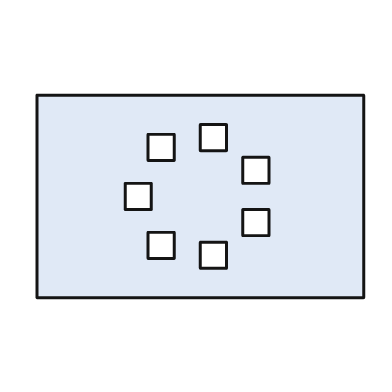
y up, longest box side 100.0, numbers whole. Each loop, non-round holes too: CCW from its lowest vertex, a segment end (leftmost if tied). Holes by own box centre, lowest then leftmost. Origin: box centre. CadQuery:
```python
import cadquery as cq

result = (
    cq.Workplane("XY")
    .moveTo(-50.0, -31.0)
    .lineTo(50.0, -31.0)
    .lineTo(50.0, 31.0)
    .lineTo(-50.0, 31.0)
    .close()
    .moveTo(0.0, -22.0)
    .lineTo(8.0, -22.0)
    .lineTo(8.0, -14.0)
    .lineTo(0.0, -14.0)
    .close()
    .moveTo(-16.0, -19.0)
    .lineTo(-8.0, -19.0)
    .lineTo(-8.0, -11.0)
    .lineTo(-16.0, -11.0)
    .close()
    .moveTo(13.0, -12.0)
    .lineTo(21.0, -12.0)
    .lineTo(21.0, -4.0)
    .lineTo(13.0, -4.0)
    .close()
    .moveTo(-23.0, -4.0)
    .lineTo(-15.0, -4.0)
    .lineTo(-15.0, 4.0)
    .lineTo(-23.0, 4.0)
    .close()
    .moveTo(13.0, 4.0)
    .lineTo(21.0, 4.0)
    .lineTo(21.0, 12.0)
    .lineTo(13.0, 12.0)
    .close()
    .moveTo(-16.0, 11.0)
    .lineTo(-8.0, 11.0)
    .lineTo(-8.0, 19.0)
    .lineTo(-16.0, 19.0)
    .close()
    .moveTo(0.0, 14.0)
    .lineTo(8.0, 14.0)
    .lineTo(8.0, 22.0)
    .lineTo(0.0, 22.0)
    .close()
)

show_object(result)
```